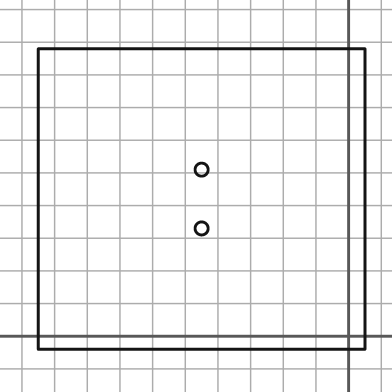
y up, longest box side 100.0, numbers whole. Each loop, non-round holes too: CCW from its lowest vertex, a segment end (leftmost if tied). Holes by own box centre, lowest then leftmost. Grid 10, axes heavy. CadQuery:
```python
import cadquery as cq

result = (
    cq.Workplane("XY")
    .moveTo(-95.0, -4.0)
    .lineTo(5.0, -4.0)
    .lineTo(5.0, 88.0)
    .lineTo(-95.0, 88.0)
    .close()
    .moveTo(-45.0, 33.0)
    .circle(2.0)
    .moveTo(-45.0, 51.0)
    .circle(2.0)
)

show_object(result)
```